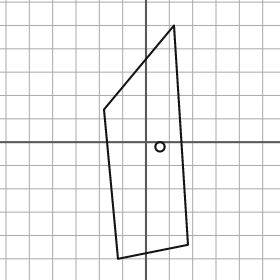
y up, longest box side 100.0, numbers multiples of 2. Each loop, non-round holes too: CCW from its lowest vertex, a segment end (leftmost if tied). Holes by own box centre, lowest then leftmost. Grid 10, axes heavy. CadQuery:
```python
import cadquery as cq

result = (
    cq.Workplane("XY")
    .moveTo(-12.0, -50.0)
    .lineTo(18.0, -44.0)
    .lineTo(12.0, 50.0)
    .lineTo(-18.0, 14.0)
    .close()
    .moveTo(6.0, -2.0)
    .circle(2.0)
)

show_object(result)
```